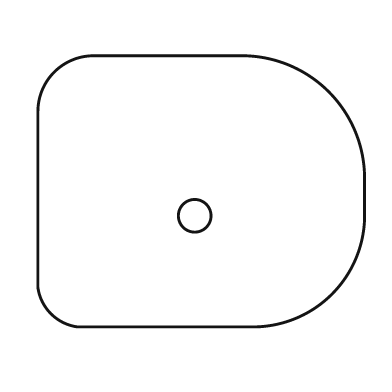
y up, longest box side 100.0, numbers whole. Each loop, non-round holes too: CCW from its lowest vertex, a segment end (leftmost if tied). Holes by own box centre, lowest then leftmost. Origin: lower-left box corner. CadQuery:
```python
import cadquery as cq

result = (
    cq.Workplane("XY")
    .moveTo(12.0, 0.0)
    .lineTo(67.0, 0.0)
    .threePointArc((90.0, 10.0), (100.0, 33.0))
    .lineTo(100.0, 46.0)
    .threePointArc((89.0, 72.0), (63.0, 83.0))
    .lineTo(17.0, 83.0)
    .threePointArc((5.0, 78.0), (0.0, 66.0))
    .lineTo(0.0, 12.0)
    .threePointArc((4.0, 4.0), (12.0, 0.0))
    .close()
    .moveTo(48.0, 34.0)
    .circle(5.0)
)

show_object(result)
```